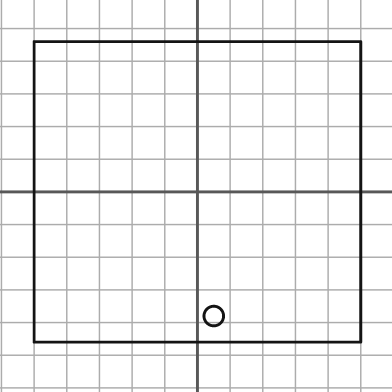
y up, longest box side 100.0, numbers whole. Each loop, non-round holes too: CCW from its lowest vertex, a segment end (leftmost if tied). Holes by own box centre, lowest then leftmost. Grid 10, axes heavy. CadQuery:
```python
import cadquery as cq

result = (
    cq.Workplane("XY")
    .moveTo(-50.0, -46.0)
    .lineTo(50.0, -46.0)
    .lineTo(50.0, 46.0)
    .lineTo(-50.0, 46.0)
    .close()
    .moveTo(5.0, -38.0)
    .circle(3.0)
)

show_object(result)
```